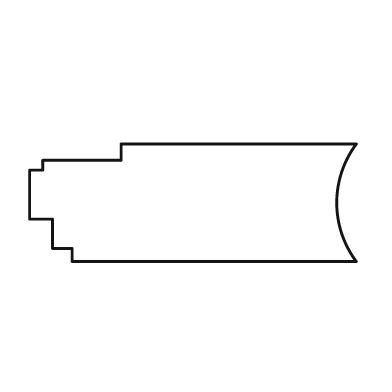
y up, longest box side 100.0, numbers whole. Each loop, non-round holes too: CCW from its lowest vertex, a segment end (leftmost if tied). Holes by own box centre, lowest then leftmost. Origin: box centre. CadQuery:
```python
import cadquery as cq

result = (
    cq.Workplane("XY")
    .moveTo(-37.0, -18.0)
    .lineTo(50.0, -18.0)
    .threePointArc((44.0, 0.0), (50.0, 18.0))
    .lineTo(-22.0, 18.0)
    .lineTo(-22.0, 13.0)
    .lineTo(-46.0, 13.0)
    .lineTo(-46.0, 10.0)
    .lineTo(-50.0, 10.0)
    .lineTo(-50.0, -5.0)
    .lineTo(-43.0, -5.0)
    .lineTo(-43.0, -14.0)
    .lineTo(-37.0, -14.0)
    .close()
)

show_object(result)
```